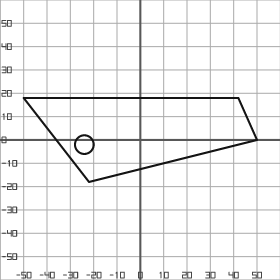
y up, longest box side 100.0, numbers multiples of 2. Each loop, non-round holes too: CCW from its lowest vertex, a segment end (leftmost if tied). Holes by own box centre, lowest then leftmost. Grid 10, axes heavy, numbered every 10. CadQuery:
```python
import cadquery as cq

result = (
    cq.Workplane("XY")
    .moveTo(-22.0, -18.0)
    .lineTo(50.0, 0.0)
    .lineTo(42.0, 18.0)
    .lineTo(-50.0, 18.0)
    .close()
    .moveTo(-24.0, -2.0)
    .circle(4.0)
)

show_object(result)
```